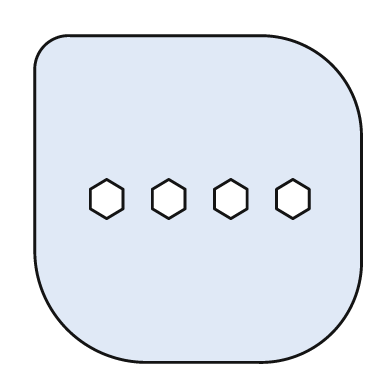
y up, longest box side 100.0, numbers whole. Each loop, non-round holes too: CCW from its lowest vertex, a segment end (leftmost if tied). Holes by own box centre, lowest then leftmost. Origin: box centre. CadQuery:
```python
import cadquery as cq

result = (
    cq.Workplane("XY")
    .moveTo(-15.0, -50.0)
    .lineTo(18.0, -50.0)
    .threePointArc((41.0, -41.0), (50.0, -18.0))
    .lineTo(50.0, 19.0)
    .threePointArc((41.0, 41.0), (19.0, 50.0))
    .lineTo(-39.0, 50.0)
    .threePointArc((-47.0, 47.0), (-50.0, 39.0))
    .lineTo(-50.0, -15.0)
    .threePointArc((-40.0, -40.0), (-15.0, -50.0))
    .close()
    .moveTo(-28.0, -6.0)
    .lineTo(-23.0, -3.0)
    .lineTo(-23.0, 3.0)
    .lineTo(-28.0, 6.0)
    .lineTo(-33.0, 3.0)
    .lineTo(-33.0, -3.0)
    .close()
    .moveTo(-9.0, -6.0)
    .lineTo(-4.0, -3.0)
    .lineTo(-4.0, 3.0)
    .lineTo(-9.0, 6.0)
    .lineTo(-14.0, 3.0)
    .lineTo(-14.0, -3.0)
    .close()
    .moveTo(10.0, -6.0)
    .lineTo(15.0, -3.0)
    .lineTo(15.0, 3.0)
    .lineTo(10.0, 6.0)
    .lineTo(5.0, 3.0)
    .lineTo(5.0, -3.0)
    .close()
    .moveTo(29.0, -6.0)
    .lineTo(34.0, -3.0)
    .lineTo(34.0, 3.0)
    .lineTo(29.0, 6.0)
    .lineTo(24.0, 3.0)
    .lineTo(24.0, -3.0)
    .close()
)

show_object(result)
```